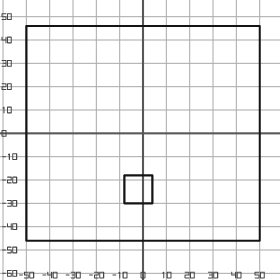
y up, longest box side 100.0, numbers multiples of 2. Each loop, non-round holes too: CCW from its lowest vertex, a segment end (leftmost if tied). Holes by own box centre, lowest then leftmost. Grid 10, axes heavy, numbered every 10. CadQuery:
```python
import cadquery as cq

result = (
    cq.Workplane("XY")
    .moveTo(-50.0, -46.0)
    .lineTo(50.0, -46.0)
    .lineTo(50.0, 46.0)
    .lineTo(-50.0, 46.0)
    .close()
    .moveTo(-8.0, -30.0)
    .lineTo(4.0, -30.0)
    .lineTo(4.0, -18.0)
    .lineTo(-8.0, -18.0)
    .close()
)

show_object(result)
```